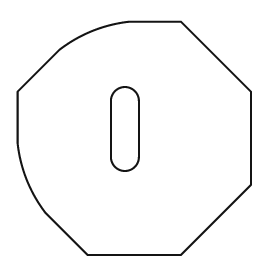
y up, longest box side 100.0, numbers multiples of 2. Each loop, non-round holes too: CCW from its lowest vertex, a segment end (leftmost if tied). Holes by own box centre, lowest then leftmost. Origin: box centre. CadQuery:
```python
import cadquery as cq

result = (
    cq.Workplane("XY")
    .moveTo(-20.0, -50.0)
    .lineTo(20.0, -50.0)
    .lineTo(50.0, -20.0)
    .lineTo(50.0, 20.0)
    .lineTo(20.0, 50.0)
    .lineTo(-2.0, 50.0)
    .threePointArc((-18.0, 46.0), (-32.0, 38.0))
    .lineTo(-50.0, 20.0)
    .lineTo(-50.0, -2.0)
    .threePointArc((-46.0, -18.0), (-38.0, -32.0))
    .close()
    .moveTo(-10.0, -8.0)
    .threePointArc((-4.0, -14.0), (2.0, -8.0))
    .lineTo(2.0, 16.0)
    .threePointArc((-4.0, 22.0), (-10.0, 16.0))
    .close()
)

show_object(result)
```